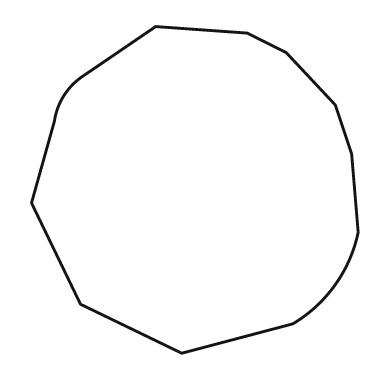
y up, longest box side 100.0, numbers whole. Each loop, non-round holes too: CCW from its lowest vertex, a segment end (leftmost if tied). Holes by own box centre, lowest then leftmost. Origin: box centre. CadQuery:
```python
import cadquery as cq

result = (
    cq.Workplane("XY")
    .moveTo(-4.0, -50.0)
    .lineTo(30.0, -41.0)
    .threePointArc((43.0, -29.0), (50.0, -13.0))
    .lineTo(48.0, 11.0)
    .lineTo(43.0, 26.0)
    .lineTo(28.0, 42.0)
    .lineTo(16.0, 48.0)
    .lineTo(-12.0, 50.0)
    .lineTo(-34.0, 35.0)
    .threePointArc((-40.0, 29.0), (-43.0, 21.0))
    .lineTo(-50.0, -4.0)
    .lineTo(-35.0, -35.0)
    .close()
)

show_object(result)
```